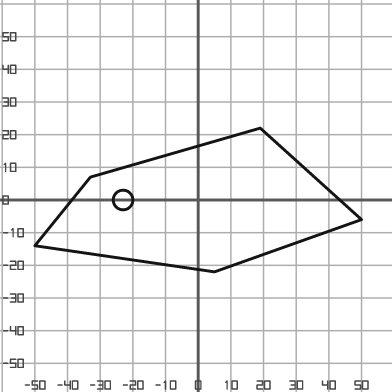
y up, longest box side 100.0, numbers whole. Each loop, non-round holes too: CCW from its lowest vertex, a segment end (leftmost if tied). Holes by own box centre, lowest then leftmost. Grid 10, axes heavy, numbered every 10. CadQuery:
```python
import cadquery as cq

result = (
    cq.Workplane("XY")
    .moveTo(5.0, -22.0)
    .lineTo(50.0, -6.0)
    .lineTo(19.0, 22.0)
    .lineTo(-33.0, 7.0)
    .lineTo(-50.0, -14.0)
    .close()
    .moveTo(-23.0, 0.0)
    .circle(3.0)
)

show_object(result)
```